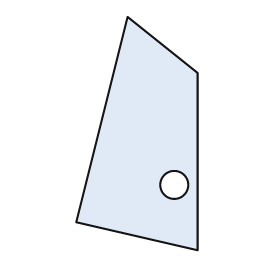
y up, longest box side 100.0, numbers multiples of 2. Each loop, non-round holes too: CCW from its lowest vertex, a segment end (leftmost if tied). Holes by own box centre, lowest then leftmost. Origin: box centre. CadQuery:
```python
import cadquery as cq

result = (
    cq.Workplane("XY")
    .moveTo(26.0, -50.0)
    .lineTo(26.0, 26.0)
    .lineTo(-4.0, 50.0)
    .lineTo(-26.0, -38.0)
    .close()
    .moveTo(16.0, -22.0)
    .circle(6.0)
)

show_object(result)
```